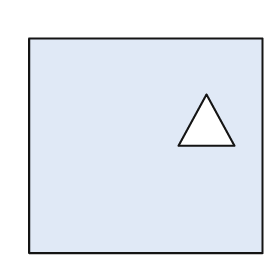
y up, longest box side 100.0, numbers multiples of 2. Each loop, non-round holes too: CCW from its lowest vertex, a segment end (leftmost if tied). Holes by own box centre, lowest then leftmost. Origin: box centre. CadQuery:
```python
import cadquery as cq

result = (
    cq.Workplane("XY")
    .moveTo(-50.0, -46.0)
    .lineTo(50.0, -46.0)
    .lineTo(50.0, 46.0)
    .lineTo(-50.0, 46.0)
    .close()
    .moveTo(14.0, 0.0)
    .lineTo(38.0, 0.0)
    .lineTo(26.0, 22.0)
    .close()
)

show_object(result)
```